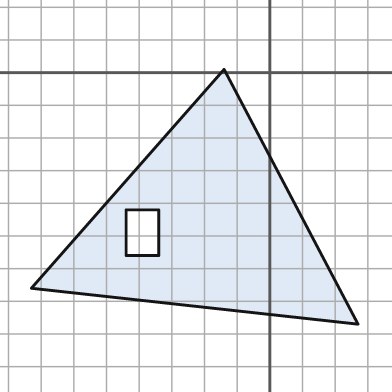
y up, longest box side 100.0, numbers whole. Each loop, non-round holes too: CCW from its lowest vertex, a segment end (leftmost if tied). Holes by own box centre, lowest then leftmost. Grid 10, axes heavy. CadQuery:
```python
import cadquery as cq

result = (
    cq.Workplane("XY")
    .moveTo(27.0, -77.0)
    .lineTo(-14.0, 1.0)
    .lineTo(-73.0, -66.0)
    .close()
    .moveTo(-44.0, -56.0)
    .lineTo(-34.0, -56.0)
    .lineTo(-34.0, -42.0)
    .lineTo(-44.0, -42.0)
    .close()
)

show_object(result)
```